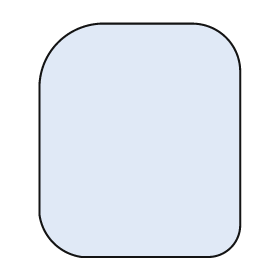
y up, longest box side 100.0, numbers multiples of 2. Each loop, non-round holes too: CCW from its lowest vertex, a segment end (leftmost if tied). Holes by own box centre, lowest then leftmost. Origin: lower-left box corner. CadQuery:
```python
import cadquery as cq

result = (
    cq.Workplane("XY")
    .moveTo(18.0, 0.0)
    .lineTo(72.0, 0.0)
    .threePointArc((82.0, 4.0), (86.0, 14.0))
    .lineTo(86.0, 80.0)
    .threePointArc((80.0, 94.0), (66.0, 100.0))
    .lineTo(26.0, 100.0)
    .threePointArc((8.0, 92.0), (0.0, 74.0))
    .lineTo(0.0, 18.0)
    .threePointArc((6.0, 6.0), (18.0, 0.0))
    .close()
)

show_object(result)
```